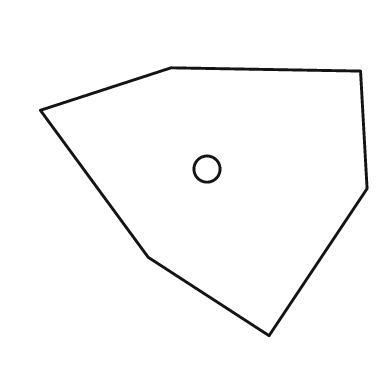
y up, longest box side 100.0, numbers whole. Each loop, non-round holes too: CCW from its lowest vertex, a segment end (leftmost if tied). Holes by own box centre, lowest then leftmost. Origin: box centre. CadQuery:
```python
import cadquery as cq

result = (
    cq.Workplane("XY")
    .moveTo(20.0, -41.0)
    .lineTo(50.0, 4.0)
    .lineTo(48.0, 40.0)
    .lineTo(-10.0, 41.0)
    .lineTo(-50.0, 28.0)
    .lineTo(-17.0, -17.0)
    .close()
    .moveTo(1.0, 10.0)
    .circle(4.0)
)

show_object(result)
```